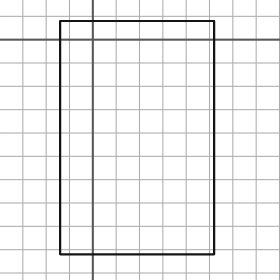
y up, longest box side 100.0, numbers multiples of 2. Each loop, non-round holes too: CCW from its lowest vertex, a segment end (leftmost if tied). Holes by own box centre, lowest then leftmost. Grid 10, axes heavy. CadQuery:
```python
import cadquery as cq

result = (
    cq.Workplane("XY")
    .moveTo(-14.0, -92.0)
    .lineTo(52.0, -92.0)
    .lineTo(52.0, 8.0)
    .lineTo(-14.0, 8.0)
    .close()
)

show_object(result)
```